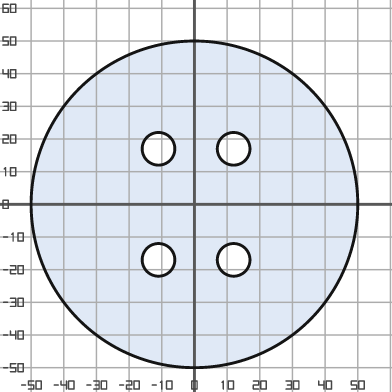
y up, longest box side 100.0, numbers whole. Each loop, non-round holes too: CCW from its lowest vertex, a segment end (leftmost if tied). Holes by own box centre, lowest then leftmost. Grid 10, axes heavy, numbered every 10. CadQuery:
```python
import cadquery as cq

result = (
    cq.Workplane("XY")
    .moveTo(0.0, 0.0)
    .circle(50.0)
    .moveTo(-11.0, -17.0)
    .circle(5.0)
    .moveTo(12.0, -17.0)
    .circle(5.0)
    .moveTo(-11.0, 17.0)
    .circle(5.0)
    .moveTo(12.0, 17.0)
    .circle(5.0)
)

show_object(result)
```